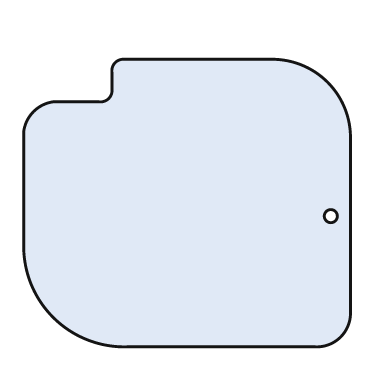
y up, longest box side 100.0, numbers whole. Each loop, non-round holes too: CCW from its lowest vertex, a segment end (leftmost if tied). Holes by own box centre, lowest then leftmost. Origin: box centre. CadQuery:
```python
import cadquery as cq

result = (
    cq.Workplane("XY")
    .moveTo(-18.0, -44.0)
    .lineTo(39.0, -44.0)
    .threePointArc((47.0, -41.0), (50.0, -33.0))
    .lineTo(50.0, 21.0)
    .threePointArc((43.0, 37.0), (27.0, 44.0))
    .lineTo(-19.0, 44.0)
    .threePointArc((-22.0, 43.0), (-23.0, 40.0))
    .lineTo(-23.0, 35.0)
    .threePointArc((-24.0, 32.0), (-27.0, 31.0))
    .lineTo(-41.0, 31.0)
    .threePointArc((-47.0, 28.0), (-50.0, 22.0))
    .lineTo(-50.0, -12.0)
    .threePointArc((-41.0, -35.0), (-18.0, -44.0))
    .close()
    .moveTo(44.0, -4.0)
    .circle(2.0)
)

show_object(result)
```